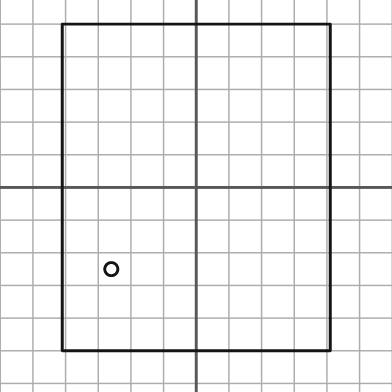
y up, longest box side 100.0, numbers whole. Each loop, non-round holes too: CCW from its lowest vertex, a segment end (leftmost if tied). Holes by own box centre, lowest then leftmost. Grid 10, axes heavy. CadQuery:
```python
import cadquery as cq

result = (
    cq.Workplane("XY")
    .moveTo(-41.0, -50.0)
    .lineTo(41.0, -50.0)
    .lineTo(41.0, 50.0)
    .lineTo(-41.0, 50.0)
    .close()
    .moveTo(-26.0, -25.0)
    .circle(2.0)
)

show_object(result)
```